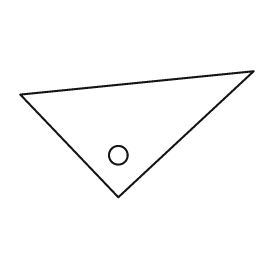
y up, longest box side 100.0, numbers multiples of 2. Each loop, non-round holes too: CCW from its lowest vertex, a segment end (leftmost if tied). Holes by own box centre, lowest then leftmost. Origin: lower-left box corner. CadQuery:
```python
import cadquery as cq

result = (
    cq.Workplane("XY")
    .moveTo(42.0, 0.0)
    .lineTo(100.0, 54.0)
    .lineTo(0.0, 44.0)
    .close()
    .moveTo(42.0, 18.0)
    .circle(4.0)
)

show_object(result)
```